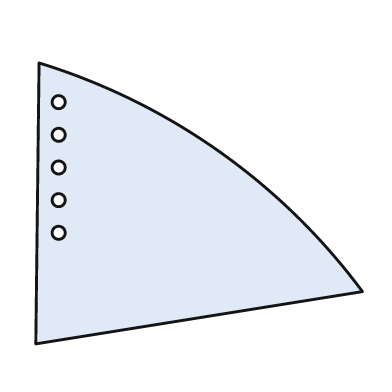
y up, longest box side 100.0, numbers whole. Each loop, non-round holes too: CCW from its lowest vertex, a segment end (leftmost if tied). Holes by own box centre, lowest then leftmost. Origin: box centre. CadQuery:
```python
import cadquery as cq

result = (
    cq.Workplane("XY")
    .moveTo(-50.0, -43.0)
    .lineTo(50.0, -27.0)
    .threePointArc((6.0, 16.0), (-49.0, 43.0))
    .close()
    .moveTo(-43.0, -9.0)
    .circle(2.0)
    .moveTo(-43.0, 1.0)
    .circle(2.0)
    .moveTo(-43.0, 11.0)
    .circle(2.0)
    .moveTo(-43.0, 21.0)
    .circle(2.0)
    .moveTo(-43.0, 31.0)
    .circle(2.0)
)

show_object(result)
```